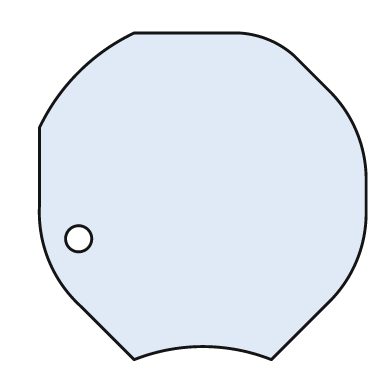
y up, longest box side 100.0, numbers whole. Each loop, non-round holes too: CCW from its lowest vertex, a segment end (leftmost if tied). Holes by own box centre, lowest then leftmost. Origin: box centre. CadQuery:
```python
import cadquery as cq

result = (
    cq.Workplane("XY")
    .moveTo(-21.0, -50.0)
    .threePointArc((0.0, -46.0), (21.0, -50.0))
    .lineTo(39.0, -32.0)
    .threePointArc((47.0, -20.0), (50.0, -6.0))
    .lineTo(50.0, 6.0)
    .threePointArc((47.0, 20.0), (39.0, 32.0))
    .lineTo(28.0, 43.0)
    .threePointArc((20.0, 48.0), (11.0, 50.0))
    .lineTo(-21.0, 50.0)
    .threePointArc((-38.0, 38.0), (-50.0, 21.0))
    .lineTo(-50.0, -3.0)
    .threePointArc((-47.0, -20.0), (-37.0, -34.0))
    .close()
    .moveTo(-38.0, -13.0)
    .circle(4.0)
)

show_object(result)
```